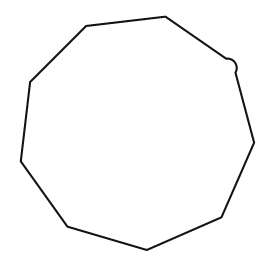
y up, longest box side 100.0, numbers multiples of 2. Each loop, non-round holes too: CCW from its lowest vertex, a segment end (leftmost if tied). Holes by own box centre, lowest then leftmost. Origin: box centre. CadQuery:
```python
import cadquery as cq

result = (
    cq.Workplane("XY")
    .moveTo(4.0, -50.0)
    .lineTo(36.0, -36.0)
    .lineTo(50.0, -4.0)
    .lineTo(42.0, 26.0)
    .threePointArc((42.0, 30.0), (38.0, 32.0))
    .lineTo(12.0, 50.0)
    .lineTo(-22.0, 46.0)
    .lineTo(-46.0, 22.0)
    .lineTo(-50.0, -12.0)
    .lineTo(-30.0, -40.0)
    .close()
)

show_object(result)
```